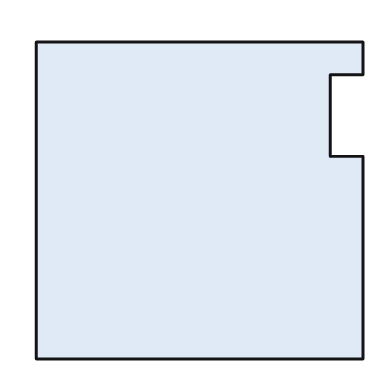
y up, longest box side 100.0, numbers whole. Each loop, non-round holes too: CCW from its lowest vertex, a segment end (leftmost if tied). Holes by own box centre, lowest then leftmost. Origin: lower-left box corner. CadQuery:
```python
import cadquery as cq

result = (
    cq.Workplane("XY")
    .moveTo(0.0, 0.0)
    .lineTo(100.0, 0.0)
    .lineTo(100.0, 62.0)
    .lineTo(90.0, 62.0)
    .lineTo(90.0, 87.0)
    .lineTo(100.0, 87.0)
    .lineTo(100.0, 97.0)
    .lineTo(0.0, 97.0)
    .close()
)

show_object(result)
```